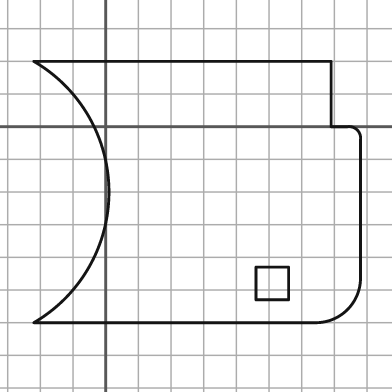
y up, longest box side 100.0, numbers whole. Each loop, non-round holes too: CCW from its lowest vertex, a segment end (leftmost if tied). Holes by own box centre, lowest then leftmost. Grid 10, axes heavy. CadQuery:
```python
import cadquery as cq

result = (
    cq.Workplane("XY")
    .moveTo(-22.0, -60.0)
    .lineTo(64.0, -60.0)
    .threePointArc((74.0, -56.0), (78.0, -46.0))
    .lineTo(78.0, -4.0)
    .threePointArc((77.0, -1.0), (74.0, 0.0))
    .lineTo(69.0, 0.0)
    .lineTo(69.0, 20.0)
    .lineTo(-22.0, 20.0)
    .threePointArc((1.0, -20.0), (-22.0, -60.0))
    .close()
    .moveTo(46.0, -53.0)
    .lineTo(56.0, -53.0)
    .lineTo(56.0, -43.0)
    .lineTo(46.0, -43.0)
    .close()
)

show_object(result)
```